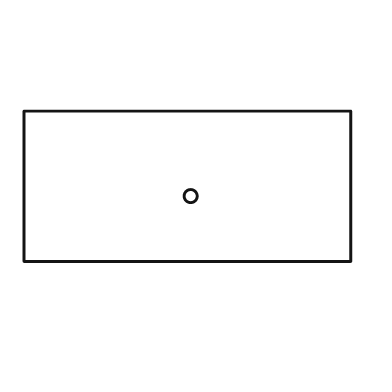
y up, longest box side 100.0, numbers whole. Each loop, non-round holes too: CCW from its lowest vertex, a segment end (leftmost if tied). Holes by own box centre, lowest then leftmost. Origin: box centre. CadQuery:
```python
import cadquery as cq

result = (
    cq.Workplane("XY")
    .moveTo(-50.0, -23.0)
    .lineTo(50.0, -23.0)
    .lineTo(50.0, 23.0)
    .lineTo(-50.0, 23.0)
    .close()
    .moveTo(1.0, -3.0)
    .circle(2.0)
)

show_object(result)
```